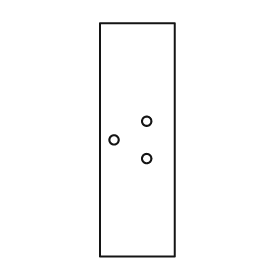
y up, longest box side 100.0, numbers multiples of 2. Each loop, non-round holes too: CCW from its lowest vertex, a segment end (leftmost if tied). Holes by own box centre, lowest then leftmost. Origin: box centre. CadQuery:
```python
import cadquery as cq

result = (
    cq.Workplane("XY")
    .moveTo(-16.0, -50.0)
    .lineTo(16.0, -50.0)
    .lineTo(16.0, 50.0)
    .lineTo(-16.0, 50.0)
    .close()
    .moveTo(4.0, -8.0)
    .circle(2.0)
    .moveTo(-10.0, 0.0)
    .circle(2.0)
    .moveTo(4.0, 8.0)
    .circle(2.0)
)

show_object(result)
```